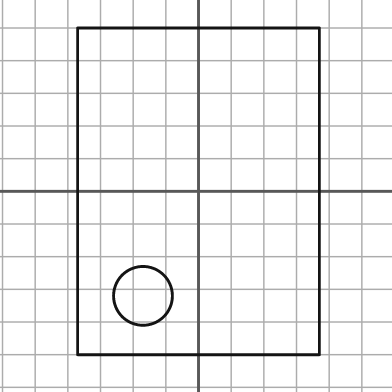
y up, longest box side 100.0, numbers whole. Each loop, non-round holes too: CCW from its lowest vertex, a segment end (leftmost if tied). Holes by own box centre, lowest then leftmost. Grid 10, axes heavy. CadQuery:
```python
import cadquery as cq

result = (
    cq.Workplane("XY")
    .moveTo(-37.0, -50.0)
    .lineTo(37.0, -50.0)
    .lineTo(37.0, 50.0)
    .lineTo(-37.0, 50.0)
    .close()
    .moveTo(-17.0, -32.0)
    .circle(9.0)
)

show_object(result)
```